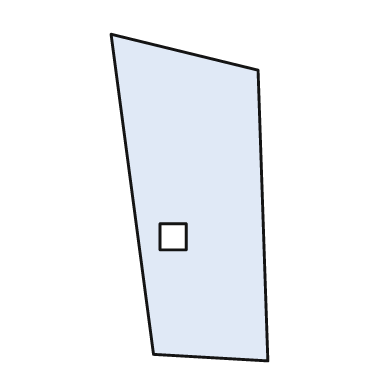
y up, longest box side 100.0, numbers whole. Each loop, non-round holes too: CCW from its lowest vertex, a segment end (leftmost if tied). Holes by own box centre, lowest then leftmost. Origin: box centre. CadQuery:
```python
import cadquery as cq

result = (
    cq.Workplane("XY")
    .moveTo(24.0, -50.0)
    .lineTo(21.0, 39.0)
    .lineTo(-24.0, 50.0)
    .lineTo(-11.0, -48.0)
    .close()
    .moveTo(-9.0, -16.0)
    .lineTo(-1.0, -16.0)
    .lineTo(-1.0, -8.0)
    .lineTo(-9.0, -8.0)
    .close()
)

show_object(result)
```